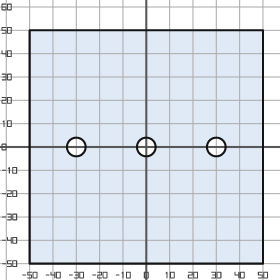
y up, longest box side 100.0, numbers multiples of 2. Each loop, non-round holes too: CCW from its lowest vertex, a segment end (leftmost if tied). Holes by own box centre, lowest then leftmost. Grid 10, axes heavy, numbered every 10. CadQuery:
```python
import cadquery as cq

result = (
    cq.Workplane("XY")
    .moveTo(-50.0, -50.0)
    .lineTo(50.0, -50.0)
    .lineTo(50.0, 50.0)
    .lineTo(-50.0, 50.0)
    .close()
    .moveTo(-30.0, 0.0)
    .circle(4.0)
    .moveTo(0.0, 0.0)
    .circle(4.0)
    .moveTo(30.0, 0.0)
    .circle(4.0)
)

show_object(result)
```